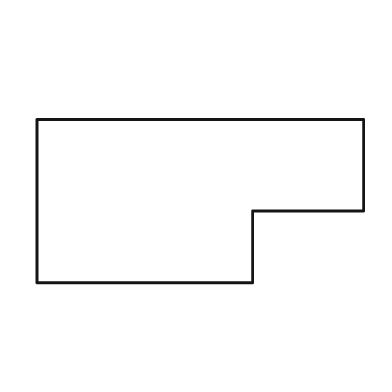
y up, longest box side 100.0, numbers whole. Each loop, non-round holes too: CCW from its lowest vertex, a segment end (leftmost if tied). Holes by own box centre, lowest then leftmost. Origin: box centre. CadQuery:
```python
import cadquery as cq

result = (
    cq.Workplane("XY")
    .moveTo(-50.0, -25.0)
    .lineTo(16.0, -25.0)
    .lineTo(16.0, -3.0)
    .lineTo(50.0, -3.0)
    .lineTo(50.0, 25.0)
    .lineTo(-50.0, 25.0)
    .close()
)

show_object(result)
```